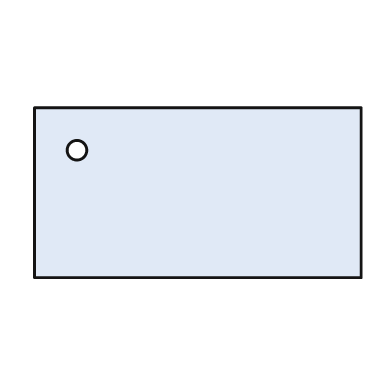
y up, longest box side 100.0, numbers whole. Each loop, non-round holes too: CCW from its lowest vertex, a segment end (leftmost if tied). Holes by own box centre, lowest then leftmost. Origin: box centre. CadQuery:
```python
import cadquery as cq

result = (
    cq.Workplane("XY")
    .moveTo(-50.0, -26.0)
    .lineTo(50.0, -26.0)
    .lineTo(50.0, 26.0)
    .lineTo(-50.0, 26.0)
    .close()
    .moveTo(-37.0, 13.0)
    .circle(3.0)
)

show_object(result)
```